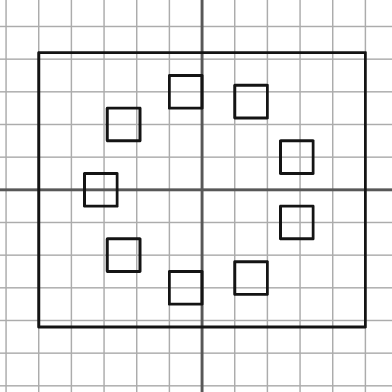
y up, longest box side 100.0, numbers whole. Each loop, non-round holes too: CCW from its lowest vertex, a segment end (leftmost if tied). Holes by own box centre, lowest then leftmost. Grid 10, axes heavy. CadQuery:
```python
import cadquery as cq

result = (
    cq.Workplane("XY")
    .moveTo(-50.0, -42.0)
    .lineTo(50.0, -42.0)
    .lineTo(50.0, 42.0)
    .lineTo(-50.0, 42.0)
    .close()
    .moveTo(-10.0, -35.0)
    .lineTo(0.0, -35.0)
    .lineTo(0.0, -25.0)
    .lineTo(-10.0, -25.0)
    .close()
    .moveTo(10.0, -32.0)
    .lineTo(20.0, -32.0)
    .lineTo(20.0, -22.0)
    .lineTo(10.0, -22.0)
    .close()
    .moveTo(-29.0, -25.0)
    .lineTo(-19.0, -25.0)
    .lineTo(-19.0, -15.0)
    .lineTo(-29.0, -15.0)
    .close()
    .moveTo(24.0, -15.0)
    .lineTo(34.0, -15.0)
    .lineTo(34.0, -5.0)
    .lineTo(24.0, -5.0)
    .close()
    .moveTo(-36.0, -5.0)
    .lineTo(-26.0, -5.0)
    .lineTo(-26.0, 5.0)
    .lineTo(-36.0, 5.0)
    .close()
    .moveTo(24.0, 5.0)
    .lineTo(34.0, 5.0)
    .lineTo(34.0, 15.0)
    .lineTo(24.0, 15.0)
    .close()
    .moveTo(-29.0, 15.0)
    .lineTo(-19.0, 15.0)
    .lineTo(-19.0, 25.0)
    .lineTo(-29.0, 25.0)
    .close()
    .moveTo(10.0, 22.0)
    .lineTo(20.0, 22.0)
    .lineTo(20.0, 32.0)
    .lineTo(10.0, 32.0)
    .close()
    .moveTo(-10.0, 25.0)
    .lineTo(0.0, 25.0)
    .lineTo(0.0, 35.0)
    .lineTo(-10.0, 35.0)
    .close()
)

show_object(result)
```